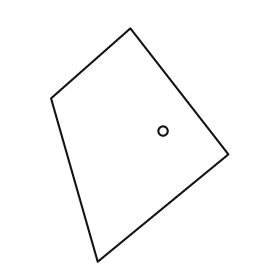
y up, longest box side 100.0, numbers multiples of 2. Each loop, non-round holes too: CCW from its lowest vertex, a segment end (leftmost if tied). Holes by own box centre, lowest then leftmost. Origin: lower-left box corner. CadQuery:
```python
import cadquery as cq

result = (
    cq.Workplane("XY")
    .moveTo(20.0, 0.0)
    .lineTo(76.0, 46.0)
    .lineTo(34.0, 100.0)
    .lineTo(0.0, 70.0)
    .close()
    .moveTo(48.0, 56.0)
    .circle(2.0)
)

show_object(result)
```